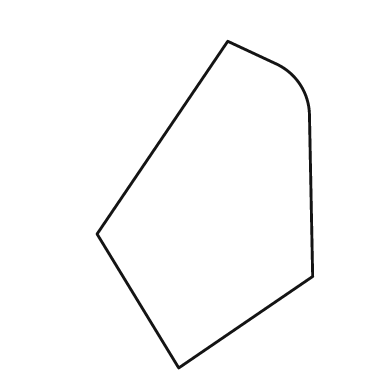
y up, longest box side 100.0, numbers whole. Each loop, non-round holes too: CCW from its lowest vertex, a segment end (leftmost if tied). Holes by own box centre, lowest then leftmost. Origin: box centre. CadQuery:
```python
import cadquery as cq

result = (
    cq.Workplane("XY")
    .moveTo(-8.0, -50.0)
    .lineTo(33.0, -22.0)
    .lineTo(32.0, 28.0)
    .threePointArc((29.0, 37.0), (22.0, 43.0))
    .lineTo(7.0, 50.0)
    .lineTo(-33.0, -9.0)
    .close()
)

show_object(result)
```